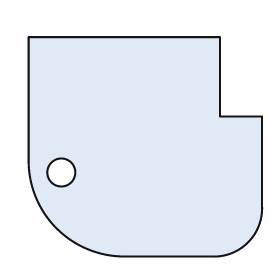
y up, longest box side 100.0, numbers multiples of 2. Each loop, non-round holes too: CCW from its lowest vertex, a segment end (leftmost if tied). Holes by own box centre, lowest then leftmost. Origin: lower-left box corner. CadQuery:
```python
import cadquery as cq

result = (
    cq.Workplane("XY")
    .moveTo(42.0, 0.0)
    .lineTo(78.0, 0.0)
    .threePointArc((94.0, 6.0), (100.0, 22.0))
    .lineTo(100.0, 60.0)
    .lineTo(82.0, 60.0)
    .lineTo(82.0, 94.0)
    .lineTo(0.0, 94.0)
    .lineTo(0.0, 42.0)
    .threePointArc((12.0, 12.0), (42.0, 0.0))
    .close()
    .moveTo(14.0, 36.0)
    .circle(6.0)
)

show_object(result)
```